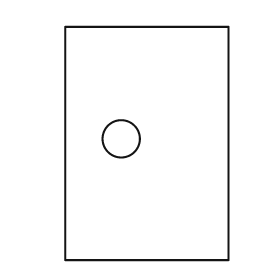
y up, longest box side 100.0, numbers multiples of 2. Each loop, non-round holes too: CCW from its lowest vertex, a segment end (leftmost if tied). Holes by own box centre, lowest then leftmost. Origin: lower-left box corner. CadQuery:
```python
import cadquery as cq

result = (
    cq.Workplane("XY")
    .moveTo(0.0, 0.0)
    .lineTo(70.0, 0.0)
    .lineTo(70.0, 100.0)
    .lineTo(0.0, 100.0)
    .close()
    .moveTo(24.0, 52.0)
    .circle(8.0)
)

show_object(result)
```